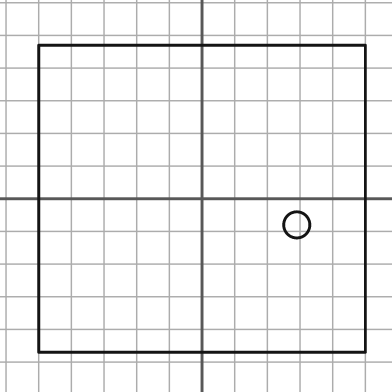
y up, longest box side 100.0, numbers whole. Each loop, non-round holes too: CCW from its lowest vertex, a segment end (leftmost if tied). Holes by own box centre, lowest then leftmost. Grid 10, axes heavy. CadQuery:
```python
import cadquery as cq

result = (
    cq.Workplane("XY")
    .moveTo(-50.0, -47.0)
    .lineTo(50.0, -47.0)
    .lineTo(50.0, 47.0)
    .lineTo(-50.0, 47.0)
    .close()
    .moveTo(29.0, -8.0)
    .circle(4.0)
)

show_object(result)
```